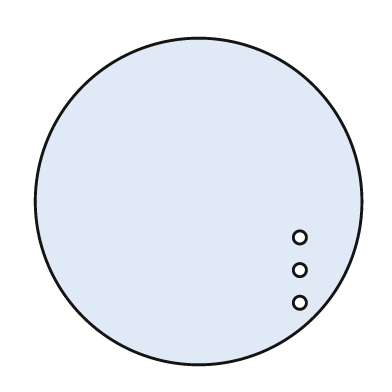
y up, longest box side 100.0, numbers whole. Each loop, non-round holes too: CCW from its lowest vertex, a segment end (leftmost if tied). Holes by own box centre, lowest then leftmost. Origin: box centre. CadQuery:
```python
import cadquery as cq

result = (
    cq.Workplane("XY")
    .moveTo(0.0, 0.0)
    .circle(50.0)
    .moveTo(31.0, -31.0)
    .circle(2.0)
    .moveTo(31.0, -21.0)
    .circle(2.0)
    .moveTo(31.0, -11.0)
    .circle(2.0)
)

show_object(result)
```